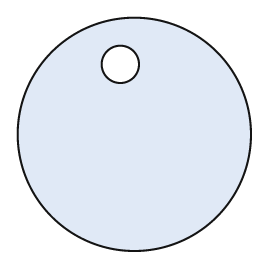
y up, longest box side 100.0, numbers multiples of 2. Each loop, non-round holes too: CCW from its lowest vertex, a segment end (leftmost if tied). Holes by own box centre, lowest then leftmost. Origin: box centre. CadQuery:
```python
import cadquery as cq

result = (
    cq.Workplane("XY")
    .moveTo(0.0, 0.0)
    .circle(50.0)
    .moveTo(-6.0, 30.0)
    .circle(8.0)
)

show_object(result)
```